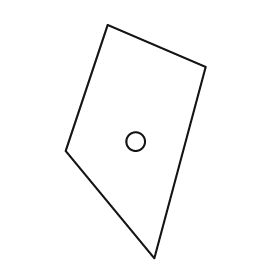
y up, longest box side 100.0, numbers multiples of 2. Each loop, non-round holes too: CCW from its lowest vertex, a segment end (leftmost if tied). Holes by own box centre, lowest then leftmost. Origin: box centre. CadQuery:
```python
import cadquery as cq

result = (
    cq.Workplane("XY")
    .moveTo(8.0, -50.0)
    .lineTo(30.0, 32.0)
    .lineTo(-12.0, 50.0)
    .lineTo(-30.0, -4.0)
    .close()
    .moveTo(0.0, 0.0)
    .circle(4.0)
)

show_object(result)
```